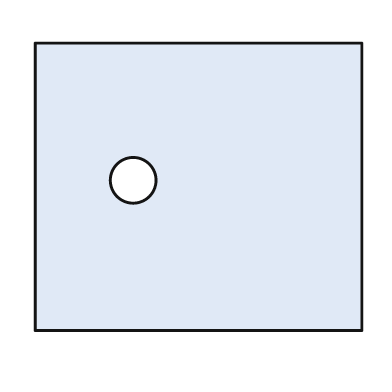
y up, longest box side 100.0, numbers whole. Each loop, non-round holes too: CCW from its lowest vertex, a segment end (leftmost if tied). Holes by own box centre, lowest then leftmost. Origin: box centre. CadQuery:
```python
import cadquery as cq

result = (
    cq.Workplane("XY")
    .moveTo(-50.0, -44.0)
    .lineTo(50.0, -44.0)
    .lineTo(50.0, 44.0)
    .lineTo(-50.0, 44.0)
    .close()
    .moveTo(-20.0, 2.0)
    .circle(7.0)
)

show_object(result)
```